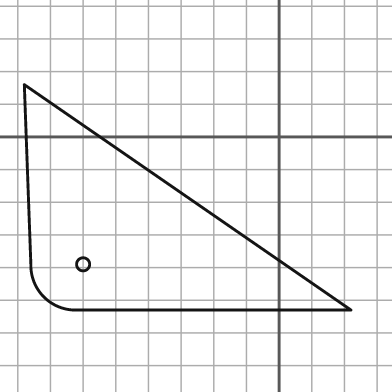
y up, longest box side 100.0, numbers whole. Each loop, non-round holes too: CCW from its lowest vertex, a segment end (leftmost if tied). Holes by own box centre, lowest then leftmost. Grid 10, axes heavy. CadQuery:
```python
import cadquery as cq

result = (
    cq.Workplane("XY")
    .moveTo(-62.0, -53.0)
    .lineTo(22.0, -53.0)
    .lineTo(-78.0, 16.0)
    .lineTo(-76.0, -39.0)
    .threePointArc((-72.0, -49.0), (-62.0, -53.0))
    .close()
    .moveTo(-60.0, -39.0)
    .circle(2.0)
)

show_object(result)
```